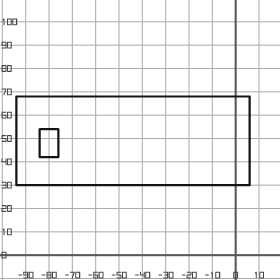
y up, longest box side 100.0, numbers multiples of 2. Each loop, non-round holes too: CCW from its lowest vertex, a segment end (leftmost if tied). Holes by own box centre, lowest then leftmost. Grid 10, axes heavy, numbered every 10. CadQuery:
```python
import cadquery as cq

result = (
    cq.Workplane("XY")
    .moveTo(-94.0, 30.0)
    .lineTo(6.0, 30.0)
    .lineTo(6.0, 68.0)
    .lineTo(-94.0, 68.0)
    .close()
    .moveTo(-84.0, 42.0)
    .lineTo(-76.0, 42.0)
    .lineTo(-76.0, 54.0)
    .lineTo(-84.0, 54.0)
    .close()
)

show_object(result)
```